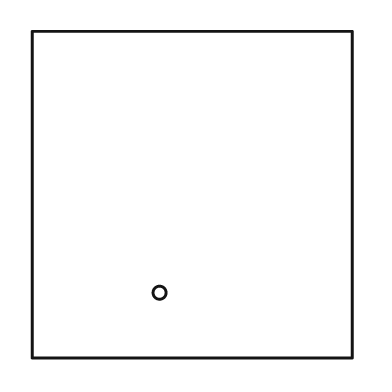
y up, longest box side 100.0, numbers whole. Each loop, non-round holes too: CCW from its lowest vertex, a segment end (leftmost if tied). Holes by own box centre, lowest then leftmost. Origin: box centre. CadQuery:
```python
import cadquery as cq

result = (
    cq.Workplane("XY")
    .moveTo(-49.0, -50.0)
    .lineTo(49.0, -50.0)
    .lineTo(49.0, 50.0)
    .lineTo(-49.0, 50.0)
    .close()
    .moveTo(-10.0, -30.0)
    .circle(2.0)
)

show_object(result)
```